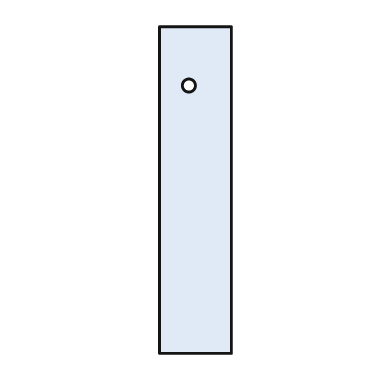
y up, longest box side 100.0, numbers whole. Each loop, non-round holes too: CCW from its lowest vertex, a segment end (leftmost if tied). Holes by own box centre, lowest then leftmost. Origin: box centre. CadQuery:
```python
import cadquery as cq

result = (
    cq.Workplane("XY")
    .moveTo(-11.0, -50.0)
    .lineTo(11.0, -50.0)
    .lineTo(11.0, 50.0)
    .lineTo(-11.0, 50.0)
    .close()
    .moveTo(-2.0, 32.0)
    .circle(2.0)
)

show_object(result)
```